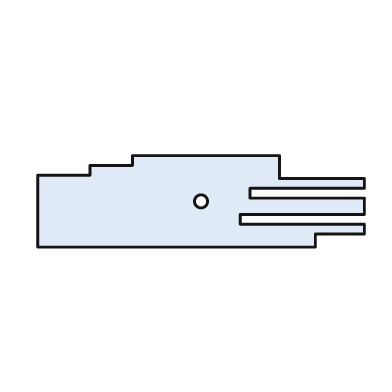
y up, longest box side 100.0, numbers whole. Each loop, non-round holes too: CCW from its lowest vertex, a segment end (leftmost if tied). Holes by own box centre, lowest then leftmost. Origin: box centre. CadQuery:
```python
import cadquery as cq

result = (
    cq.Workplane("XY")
    .moveTo(-50.0, -14.0)
    .lineTo(35.0, -14.0)
    .lineTo(35.0, -10.0)
    .lineTo(50.0, -10.0)
    .lineTo(50.0, -7.0)
    .lineTo(12.0, -7.0)
    .lineTo(12.0, -4.0)
    .lineTo(50.0, -4.0)
    .lineTo(50.0, 1.0)
    .lineTo(15.0, 1.0)
    .lineTo(15.0, 4.0)
    .lineTo(50.0, 4.0)
    .lineTo(50.0, 7.0)
    .lineTo(24.0, 7.0)
    .lineTo(24.0, 14.0)
    .lineTo(-21.0, 14.0)
    .lineTo(-21.0, 11.0)
    .lineTo(-34.0, 11.0)
    .lineTo(-34.0, 8.0)
    .lineTo(-50.0, 8.0)
    .close()
    .moveTo(0.0, 0.0)
    .circle(2.0)
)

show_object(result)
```